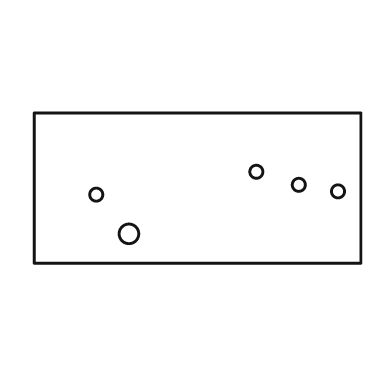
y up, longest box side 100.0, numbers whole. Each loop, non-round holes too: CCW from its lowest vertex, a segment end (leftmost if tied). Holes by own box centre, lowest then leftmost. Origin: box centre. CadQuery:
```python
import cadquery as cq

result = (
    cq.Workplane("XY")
    .moveTo(-50.0, -23.0)
    .lineTo(50.0, -23.0)
    .lineTo(50.0, 23.0)
    .lineTo(-50.0, 23.0)
    .close()
    .moveTo(-21.0, -14.0)
    .circle(3.0)
    .moveTo(-31.0, -2.0)
    .circle(2.0)
    .moveTo(43.0, -1.0)
    .circle(2.0)
    .moveTo(31.0, 1.0)
    .circle(2.0)
    .moveTo(18.0, 5.0)
    .circle(2.0)
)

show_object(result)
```